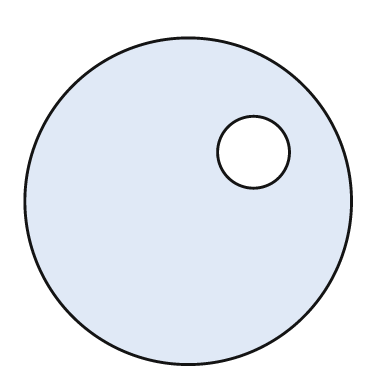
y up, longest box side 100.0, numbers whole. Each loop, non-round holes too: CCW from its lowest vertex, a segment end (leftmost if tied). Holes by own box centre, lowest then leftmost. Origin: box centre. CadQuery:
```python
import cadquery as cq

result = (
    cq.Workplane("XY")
    .moveTo(0.0, 0.0)
    .circle(50.0)
    .moveTo(20.0, 15.0)
    .circle(11.0)
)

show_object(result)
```